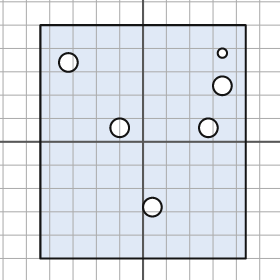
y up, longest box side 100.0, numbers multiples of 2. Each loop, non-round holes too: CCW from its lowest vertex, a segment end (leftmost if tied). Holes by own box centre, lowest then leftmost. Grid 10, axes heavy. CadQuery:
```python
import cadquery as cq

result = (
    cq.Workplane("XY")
    .moveTo(-44.0, -50.0)
    .lineTo(44.0, -50.0)
    .lineTo(44.0, 50.0)
    .lineTo(-44.0, 50.0)
    .close()
    .moveTo(4.0, -28.0)
    .circle(4.0)
    .moveTo(-10.0, 6.0)
    .circle(4.0)
    .moveTo(28.0, 6.0)
    .circle(4.0)
    .moveTo(34.0, 24.0)
    .circle(4.0)
    .moveTo(-32.0, 34.0)
    .circle(4.0)
    .moveTo(34.0, 38.0)
    .circle(2.0)
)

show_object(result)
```